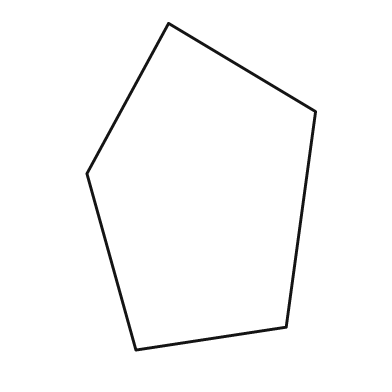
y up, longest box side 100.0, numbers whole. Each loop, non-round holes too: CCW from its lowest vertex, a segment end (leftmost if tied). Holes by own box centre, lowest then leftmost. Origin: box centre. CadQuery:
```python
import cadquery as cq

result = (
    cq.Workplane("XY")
    .moveTo(-20.0, -50.0)
    .lineTo(26.0, -43.0)
    .lineTo(35.0, 23.0)
    .lineTo(-10.0, 50.0)
    .lineTo(-35.0, 4.0)
    .close()
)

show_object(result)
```